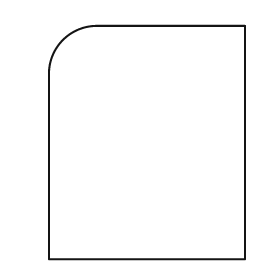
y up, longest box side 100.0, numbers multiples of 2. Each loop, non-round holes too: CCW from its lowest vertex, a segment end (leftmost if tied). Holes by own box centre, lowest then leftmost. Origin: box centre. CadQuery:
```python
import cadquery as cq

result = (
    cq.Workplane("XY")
    .moveTo(-42.0, -50.0)
    .lineTo(42.0, -50.0)
    .lineTo(42.0, 50.0)
    .lineTo(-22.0, 50.0)
    .threePointArc((-36.0, 44.0), (-42.0, 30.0))
    .close()
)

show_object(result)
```